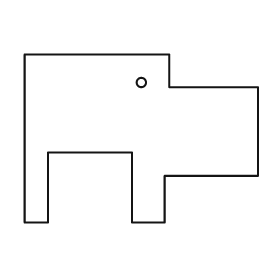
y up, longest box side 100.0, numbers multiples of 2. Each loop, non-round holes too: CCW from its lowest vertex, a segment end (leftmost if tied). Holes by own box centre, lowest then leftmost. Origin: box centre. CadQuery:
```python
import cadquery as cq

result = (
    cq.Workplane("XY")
    .moveTo(-50.0, -36.0)
    .lineTo(-40.0, -36.0)
    .lineTo(-40.0, -6.0)
    .lineTo(-4.0, -6.0)
    .lineTo(-4.0, -36.0)
    .lineTo(10.0, -36.0)
    .lineTo(10.0, -16.0)
    .lineTo(50.0, -16.0)
    .lineTo(50.0, 22.0)
    .lineTo(12.0, 22.0)
    .lineTo(12.0, 36.0)
    .lineTo(-50.0, 36.0)
    .close()
    .moveTo(0.0, 24.0)
    .circle(2.0)
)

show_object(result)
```